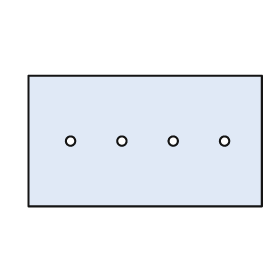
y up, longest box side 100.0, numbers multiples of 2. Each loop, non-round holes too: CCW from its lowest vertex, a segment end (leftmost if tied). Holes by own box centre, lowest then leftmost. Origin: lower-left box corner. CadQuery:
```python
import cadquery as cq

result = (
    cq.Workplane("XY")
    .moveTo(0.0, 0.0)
    .lineTo(100.0, 0.0)
    .lineTo(100.0, 56.0)
    .lineTo(0.0, 56.0)
    .close()
    .moveTo(18.0, 28.0)
    .circle(2.0)
    .moveTo(40.0, 28.0)
    .circle(2.0)
    .moveTo(62.0, 28.0)
    .circle(2.0)
    .moveTo(84.0, 28.0)
    .circle(2.0)
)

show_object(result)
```